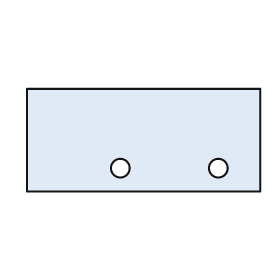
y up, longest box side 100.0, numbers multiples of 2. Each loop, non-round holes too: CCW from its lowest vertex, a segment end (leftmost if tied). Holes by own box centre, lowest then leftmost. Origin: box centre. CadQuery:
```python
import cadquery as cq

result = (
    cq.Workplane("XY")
    .moveTo(-50.0, -22.0)
    .lineTo(50.0, -22.0)
    .lineTo(50.0, 22.0)
    .lineTo(-50.0, 22.0)
    .close()
    .moveTo(-10.0, -12.0)
    .circle(4.0)
    .moveTo(32.0, -12.0)
    .circle(4.0)
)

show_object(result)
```